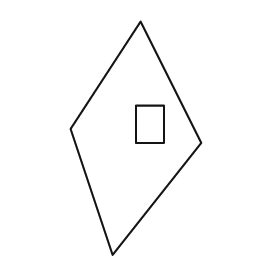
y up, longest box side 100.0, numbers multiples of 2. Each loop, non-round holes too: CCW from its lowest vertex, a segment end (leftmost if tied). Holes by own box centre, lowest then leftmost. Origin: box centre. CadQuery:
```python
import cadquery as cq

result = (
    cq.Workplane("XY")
    .moveTo(-10.0, -50.0)
    .lineTo(28.0, -2.0)
    .lineTo(2.0, 50.0)
    .lineTo(-28.0, 4.0)
    .close()
    .moveTo(0.0, -2.0)
    .lineTo(12.0, -2.0)
    .lineTo(12.0, 14.0)
    .lineTo(0.0, 14.0)
    .close()
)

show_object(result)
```